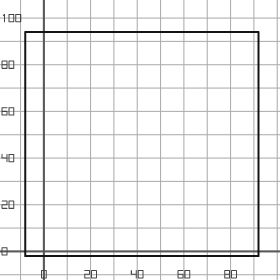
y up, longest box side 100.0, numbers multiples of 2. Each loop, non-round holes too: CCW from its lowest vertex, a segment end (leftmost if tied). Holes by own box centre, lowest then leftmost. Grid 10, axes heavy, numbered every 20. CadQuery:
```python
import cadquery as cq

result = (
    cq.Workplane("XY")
    .moveTo(-8.0, -2.0)
    .lineTo(92.0, -2.0)
    .lineTo(92.0, 94.0)
    .lineTo(-8.0, 94.0)
    .close()
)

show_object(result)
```